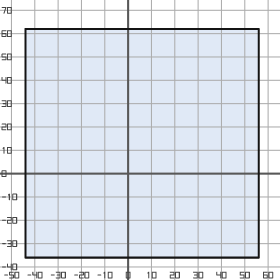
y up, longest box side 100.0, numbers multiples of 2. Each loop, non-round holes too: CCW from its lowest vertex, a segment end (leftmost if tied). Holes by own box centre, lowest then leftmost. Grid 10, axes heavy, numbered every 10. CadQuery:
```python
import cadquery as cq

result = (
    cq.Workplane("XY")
    .moveTo(-44.0, -36.0)
    .lineTo(56.0, -36.0)
    .lineTo(56.0, 62.0)
    .lineTo(-44.0, 62.0)
    .close()
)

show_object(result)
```